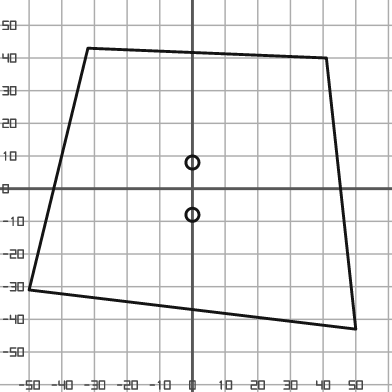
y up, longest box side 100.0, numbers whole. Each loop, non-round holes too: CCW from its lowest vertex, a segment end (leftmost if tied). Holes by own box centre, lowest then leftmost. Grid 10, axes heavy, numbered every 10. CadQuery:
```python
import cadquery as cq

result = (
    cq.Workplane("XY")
    .moveTo(50.0, -43.0)
    .lineTo(41.0, 40.0)
    .lineTo(-32.0, 43.0)
    .lineTo(-50.0, -31.0)
    .close()
    .moveTo(0.0, -8.0)
    .circle(2.0)
    .moveTo(0.0, 8.0)
    .circle(2.0)
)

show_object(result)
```